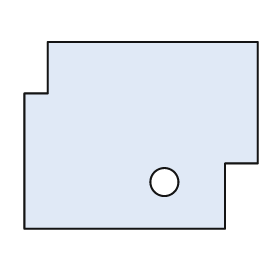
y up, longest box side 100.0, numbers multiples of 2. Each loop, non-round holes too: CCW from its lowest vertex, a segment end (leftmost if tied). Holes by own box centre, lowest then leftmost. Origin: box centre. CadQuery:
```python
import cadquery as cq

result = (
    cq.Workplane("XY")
    .moveTo(-50.0, -40.0)
    .lineTo(36.0, -40.0)
    .lineTo(36.0, -12.0)
    .lineTo(50.0, -12.0)
    .lineTo(50.0, 40.0)
    .lineTo(-40.0, 40.0)
    .lineTo(-40.0, 18.0)
    .lineTo(-50.0, 18.0)
    .close()
    .moveTo(10.0, -20.0)
    .circle(6.0)
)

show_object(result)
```